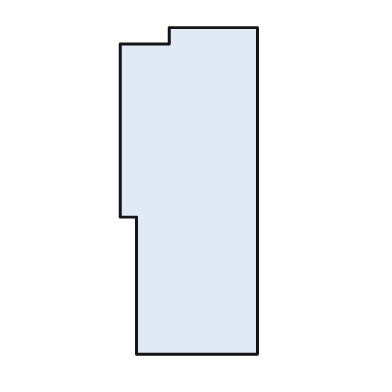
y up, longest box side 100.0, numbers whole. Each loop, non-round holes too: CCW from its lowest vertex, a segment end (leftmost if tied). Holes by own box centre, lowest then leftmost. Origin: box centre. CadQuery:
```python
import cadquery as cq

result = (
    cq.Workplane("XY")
    .moveTo(-16.0, -50.0)
    .lineTo(21.0, -50.0)
    .lineTo(21.0, 50.0)
    .lineTo(-6.0, 50.0)
    .lineTo(-6.0, 45.0)
    .lineTo(-21.0, 45.0)
    .lineTo(-21.0, -8.0)
    .lineTo(-16.0, -8.0)
    .close()
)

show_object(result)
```